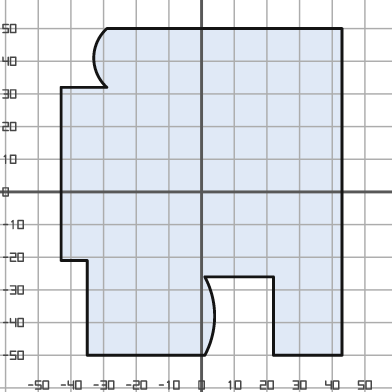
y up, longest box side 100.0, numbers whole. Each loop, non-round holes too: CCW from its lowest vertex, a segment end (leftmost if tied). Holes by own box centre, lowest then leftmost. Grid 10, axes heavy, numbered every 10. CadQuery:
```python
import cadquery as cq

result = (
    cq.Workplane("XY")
    .moveTo(-35.0, -50.0)
    .lineTo(1.0, -50.0)
    .threePointArc((4.0, -38.0), (1.0, -26.0))
    .lineTo(22.0, -26.0)
    .lineTo(22.0, -50.0)
    .lineTo(43.0, -50.0)
    .lineTo(43.0, 50.0)
    .lineTo(-29.0, 50.0)
    .threePointArc((-33.0, 41.0), (-29.0, 32.0))
    .lineTo(-43.0, 32.0)
    .lineTo(-43.0, -21.0)
    .lineTo(-35.0, -21.0)
    .close()
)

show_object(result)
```